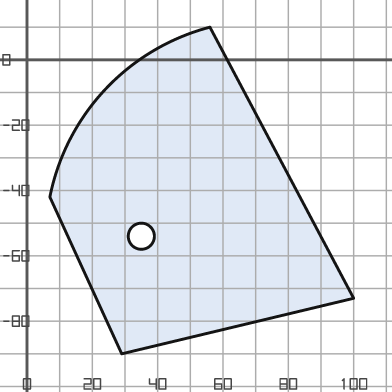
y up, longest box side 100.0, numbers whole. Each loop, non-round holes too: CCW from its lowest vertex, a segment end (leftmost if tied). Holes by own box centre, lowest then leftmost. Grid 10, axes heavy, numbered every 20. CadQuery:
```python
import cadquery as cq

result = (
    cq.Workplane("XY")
    .moveTo(29.0, -90.0)
    .lineTo(100.0, -73.0)
    .lineTo(56.0, 10.0)
    .threePointArc((24.0, -9.0), (7.0, -42.0))
    .close()
    .moveTo(35.0, -54.0)
    .circle(4.0)
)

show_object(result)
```